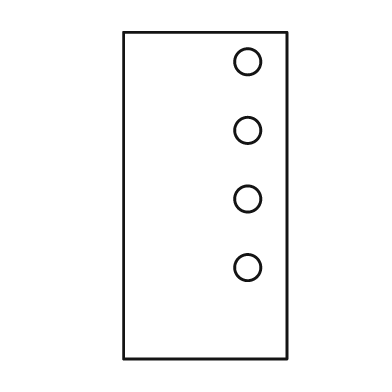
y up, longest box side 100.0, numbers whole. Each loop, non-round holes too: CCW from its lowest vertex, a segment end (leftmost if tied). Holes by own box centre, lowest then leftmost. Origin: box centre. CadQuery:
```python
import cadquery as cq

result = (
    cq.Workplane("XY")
    .moveTo(-25.0, -50.0)
    .lineTo(25.0, -50.0)
    .lineTo(25.0, 50.0)
    .lineTo(-25.0, 50.0)
    .close()
    .moveTo(13.0, -22.0)
    .circle(4.0)
    .moveTo(13.0, -1.0)
    .circle(4.0)
    .moveTo(13.0, 20.0)
    .circle(4.0)
    .moveTo(13.0, 41.0)
    .circle(4.0)
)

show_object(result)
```